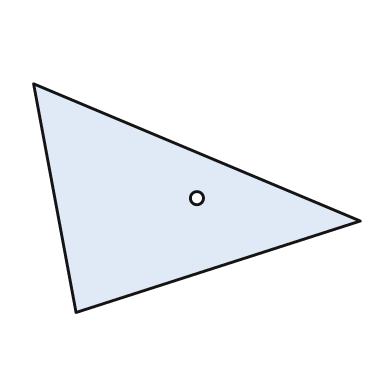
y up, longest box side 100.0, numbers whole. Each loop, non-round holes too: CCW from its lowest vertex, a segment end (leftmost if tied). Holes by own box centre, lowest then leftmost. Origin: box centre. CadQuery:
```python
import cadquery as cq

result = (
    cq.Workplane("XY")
    .moveTo(-37.0, -35.0)
    .lineTo(50.0, -7.0)
    .lineTo(-50.0, 35.0)
    .close()
    .moveTo(0.0, 0.0)
    .circle(2.0)
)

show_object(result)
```